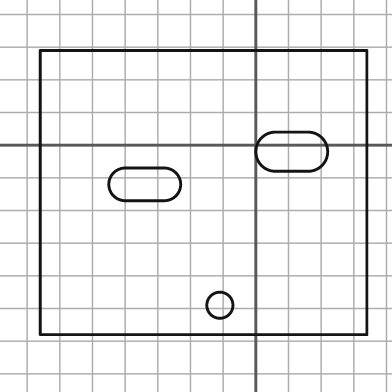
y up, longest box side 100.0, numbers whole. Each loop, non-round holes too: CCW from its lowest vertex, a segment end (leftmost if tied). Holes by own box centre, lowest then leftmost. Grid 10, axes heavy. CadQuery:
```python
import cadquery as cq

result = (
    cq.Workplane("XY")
    .moveTo(-66.0, -58.0)
    .lineTo(34.0, -58.0)
    .lineTo(34.0, 29.0)
    .lineTo(-66.0, 29.0)
    .close()
    .moveTo(-11.0, -49.0)
    .circle(4.0)
    .moveTo(-40.0, -17.0)
    .lineTo(-28.0, -17.0)
    .threePointArc((-23.0, -12.0), (-28.0, -7.0))
    .lineTo(-40.0, -7.0)
    .threePointArc((-45.0, -12.0), (-40.0, -17.0))
    .close()
    .moveTo(6.0, -8.0)
    .lineTo(16.0, -8.0)
    .threePointArc((22.0, -2.0), (16.0, 4.0))
    .lineTo(6.0, 4.0)
    .threePointArc((0.0, -2.0), (6.0, -8.0))
    .close()
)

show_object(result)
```